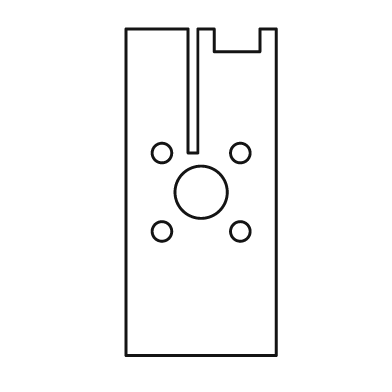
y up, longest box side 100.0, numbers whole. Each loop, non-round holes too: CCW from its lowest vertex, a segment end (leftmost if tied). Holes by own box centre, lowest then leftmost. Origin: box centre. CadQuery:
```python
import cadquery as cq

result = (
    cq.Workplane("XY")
    .moveTo(-23.0, -50.0)
    .lineTo(23.0, -50.0)
    .lineTo(23.0, 50.0)
    .lineTo(18.0, 50.0)
    .lineTo(18.0, 43.0)
    .lineTo(4.0, 43.0)
    .lineTo(4.0, 50.0)
    .lineTo(-1.0, 50.0)
    .lineTo(-1.0, 12.0)
    .lineTo(-4.0, 12.0)
    .lineTo(-4.0, 50.0)
    .lineTo(-23.0, 50.0)
    .close()
    .moveTo(-12.0, -12.0)
    .circle(3.0)
    .moveTo(12.0, -12.0)
    .circle(3.0)
    .moveTo(0.0, 0.0)
    .circle(8.0)
    .moveTo(-12.0, 12.0)
    .circle(3.0)
    .moveTo(12.0, 12.0)
    .circle(3.0)
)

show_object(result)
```